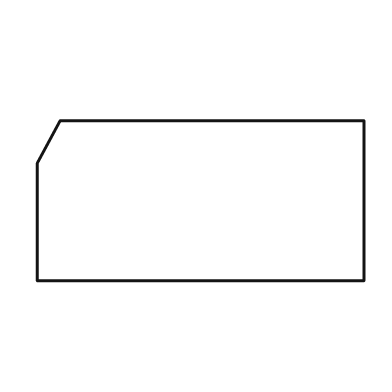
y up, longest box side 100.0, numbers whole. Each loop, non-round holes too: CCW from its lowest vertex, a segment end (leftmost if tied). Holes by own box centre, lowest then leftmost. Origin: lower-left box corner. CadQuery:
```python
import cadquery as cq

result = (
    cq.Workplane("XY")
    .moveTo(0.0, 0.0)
    .lineTo(100.0, 0.0)
    .lineTo(100.0, 49.0)
    .lineTo(7.0, 49.0)
    .lineTo(0.0, 36.0)
    .close()
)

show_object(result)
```